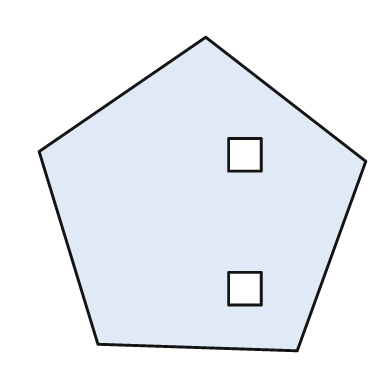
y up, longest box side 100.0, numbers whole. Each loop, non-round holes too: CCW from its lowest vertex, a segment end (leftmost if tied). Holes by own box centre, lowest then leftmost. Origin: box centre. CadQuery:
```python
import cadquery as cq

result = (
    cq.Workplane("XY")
    .moveTo(29.0, -48.0)
    .lineTo(50.0, 10.0)
    .lineTo(1.0, 48.0)
    .lineTo(-50.0, 13.0)
    .lineTo(-32.0, -46.0)
    .close()
    .moveTo(8.0, -34.0)
    .lineTo(18.0, -34.0)
    .lineTo(18.0, -24.0)
    .lineTo(8.0, -24.0)
    .close()
    .moveTo(8.0, 7.0)
    .lineTo(18.0, 7.0)
    .lineTo(18.0, 17.0)
    .lineTo(8.0, 17.0)
    .close()
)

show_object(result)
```